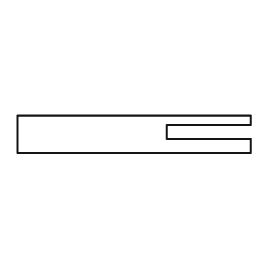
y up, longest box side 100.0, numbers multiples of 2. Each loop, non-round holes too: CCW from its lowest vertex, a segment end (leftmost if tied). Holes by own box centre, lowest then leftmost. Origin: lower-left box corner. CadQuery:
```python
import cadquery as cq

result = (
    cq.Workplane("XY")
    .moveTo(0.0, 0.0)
    .lineTo(100.0, 0.0)
    .lineTo(100.0, 6.0)
    .lineTo(64.0, 6.0)
    .lineTo(64.0, 12.0)
    .lineTo(100.0, 12.0)
    .lineTo(100.0, 16.0)
    .lineTo(0.0, 16.0)
    .close()
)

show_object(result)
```